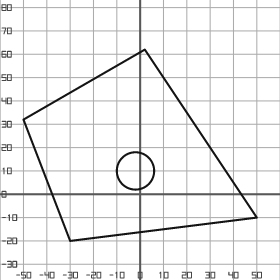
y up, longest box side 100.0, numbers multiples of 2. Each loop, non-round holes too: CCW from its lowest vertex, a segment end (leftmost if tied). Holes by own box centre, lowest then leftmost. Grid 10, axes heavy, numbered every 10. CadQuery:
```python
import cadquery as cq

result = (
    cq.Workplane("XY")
    .moveTo(-30.0, -20.0)
    .lineTo(50.0, -10.0)
    .lineTo(2.0, 62.0)
    .lineTo(-50.0, 32.0)
    .close()
    .moveTo(-2.0, 10.0)
    .circle(8.0)
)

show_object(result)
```